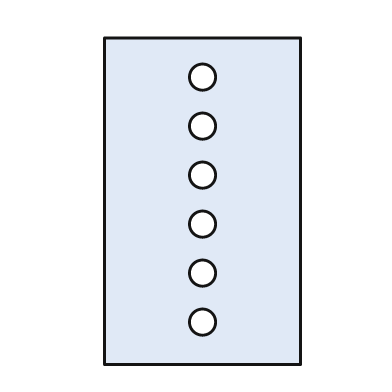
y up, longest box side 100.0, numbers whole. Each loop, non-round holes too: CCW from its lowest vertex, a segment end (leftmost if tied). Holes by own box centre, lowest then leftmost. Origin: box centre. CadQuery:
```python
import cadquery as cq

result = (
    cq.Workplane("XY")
    .moveTo(-30.0, -50.0)
    .lineTo(30.0, -50.0)
    .lineTo(30.0, 50.0)
    .lineTo(-30.0, 50.0)
    .close()
    .moveTo(0.0, -37.0)
    .circle(4.0)
    .moveTo(0.0, -22.0)
    .circle(4.0)
    .moveTo(0.0, -7.0)
    .circle(4.0)
    .moveTo(0.0, 8.0)
    .circle(4.0)
    .moveTo(0.0, 23.0)
    .circle(4.0)
    .moveTo(0.0, 38.0)
    .circle(4.0)
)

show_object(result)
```